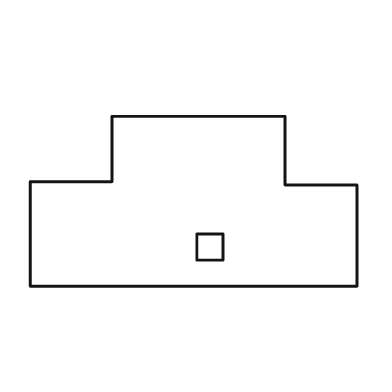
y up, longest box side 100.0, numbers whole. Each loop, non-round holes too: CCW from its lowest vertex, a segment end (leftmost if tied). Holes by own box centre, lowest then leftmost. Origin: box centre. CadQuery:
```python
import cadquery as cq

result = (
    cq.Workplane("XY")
    .moveTo(-50.0, -26.0)
    .lineTo(50.0, -26.0)
    .lineTo(50.0, 5.0)
    .lineTo(28.0, 5.0)
    .lineTo(28.0, 26.0)
    .lineTo(-25.0, 26.0)
    .lineTo(-25.0, 6.0)
    .lineTo(-50.0, 6.0)
    .close()
    .moveTo(1.0, -18.0)
    .lineTo(9.0, -18.0)
    .lineTo(9.0, -10.0)
    .lineTo(1.0, -10.0)
    .close()
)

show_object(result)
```